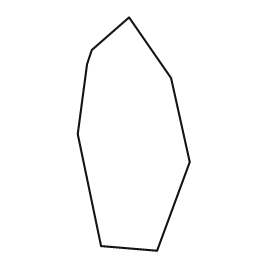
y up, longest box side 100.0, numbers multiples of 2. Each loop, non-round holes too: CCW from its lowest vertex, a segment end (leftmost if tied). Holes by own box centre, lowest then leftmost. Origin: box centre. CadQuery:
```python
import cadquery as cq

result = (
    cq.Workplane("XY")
    .moveTo(10.0, -50.0)
    .lineTo(24.0, -12.0)
    .lineTo(16.0, 24.0)
    .lineTo(-2.0, 50.0)
    .lineTo(-18.0, 36.0)
    .lineTo(-20.0, 30.0)
    .lineTo(-24.0, 0.0)
    .lineTo(-14.0, -48.0)
    .close()
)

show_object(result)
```